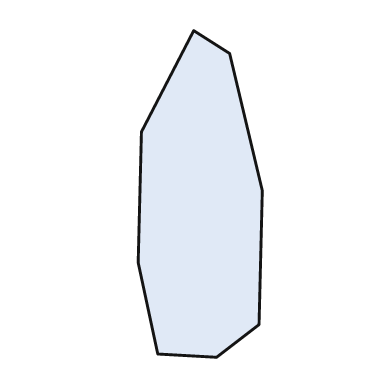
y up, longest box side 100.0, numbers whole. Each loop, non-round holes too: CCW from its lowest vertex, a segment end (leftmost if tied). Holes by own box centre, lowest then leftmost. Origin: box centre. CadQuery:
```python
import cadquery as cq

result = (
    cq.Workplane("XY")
    .moveTo(5.0, -50.0)
    .lineTo(18.0, -40.0)
    .lineTo(19.0, 1.0)
    .lineTo(9.0, 43.0)
    .lineTo(-2.0, 50.0)
    .lineTo(-18.0, 19.0)
    .lineTo(-19.0, -21.0)
    .lineTo(-13.0, -49.0)
    .close()
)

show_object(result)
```